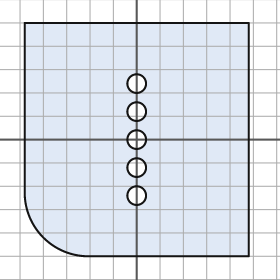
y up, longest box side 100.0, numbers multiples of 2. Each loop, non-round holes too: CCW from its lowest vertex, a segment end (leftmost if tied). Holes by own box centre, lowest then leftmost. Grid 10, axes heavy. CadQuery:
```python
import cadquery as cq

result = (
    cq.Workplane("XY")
    .moveTo(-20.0, -50.0)
    .lineTo(48.0, -50.0)
    .lineTo(48.0, 50.0)
    .lineTo(-48.0, 50.0)
    .lineTo(-48.0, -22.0)
    .threePointArc((-40.0, -42.0), (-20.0, -50.0))
    .close()
    .moveTo(0.0, -24.0)
    .circle(4.0)
    .moveTo(0.0, -12.0)
    .circle(4.0)
    .moveTo(0.0, 0.0)
    .circle(4.0)
    .moveTo(0.0, 12.0)
    .circle(4.0)
    .moveTo(0.0, 24.0)
    .circle(4.0)
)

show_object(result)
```